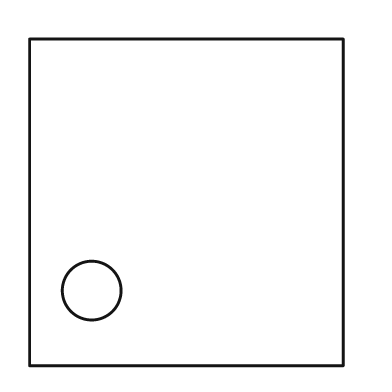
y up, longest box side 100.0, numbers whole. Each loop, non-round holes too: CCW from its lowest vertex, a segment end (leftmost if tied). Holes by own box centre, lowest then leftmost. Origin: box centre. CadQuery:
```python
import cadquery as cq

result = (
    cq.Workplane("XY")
    .moveTo(-48.0, -50.0)
    .lineTo(48.0, -50.0)
    .lineTo(48.0, 50.0)
    .lineTo(-48.0, 50.0)
    .close()
    .moveTo(-29.0, -27.0)
    .circle(9.0)
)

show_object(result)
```